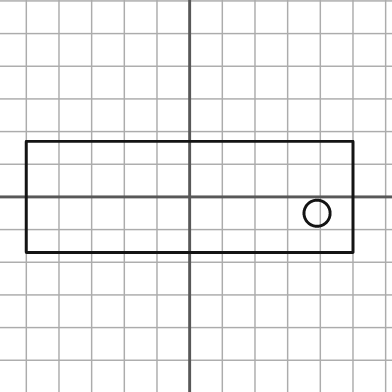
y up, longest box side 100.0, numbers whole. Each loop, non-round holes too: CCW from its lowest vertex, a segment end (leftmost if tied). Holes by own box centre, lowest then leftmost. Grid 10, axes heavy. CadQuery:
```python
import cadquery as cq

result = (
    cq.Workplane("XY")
    .moveTo(-50.0, -17.0)
    .lineTo(50.0, -17.0)
    .lineTo(50.0, 17.0)
    .lineTo(-50.0, 17.0)
    .close()
    .moveTo(39.0, -5.0)
    .circle(4.0)
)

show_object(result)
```